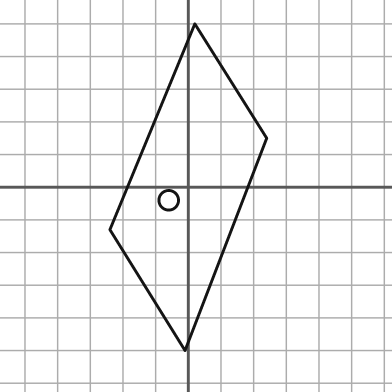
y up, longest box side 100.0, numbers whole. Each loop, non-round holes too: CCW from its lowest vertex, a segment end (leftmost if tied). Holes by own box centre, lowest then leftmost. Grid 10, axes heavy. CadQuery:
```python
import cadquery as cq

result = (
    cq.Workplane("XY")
    .moveTo(-1.0, -50.0)
    .lineTo(24.0, 15.0)
    .lineTo(2.0, 50.0)
    .lineTo(-24.0, -13.0)
    .close()
    .moveTo(-6.0, -4.0)
    .circle(3.0)
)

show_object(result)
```